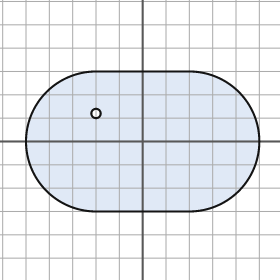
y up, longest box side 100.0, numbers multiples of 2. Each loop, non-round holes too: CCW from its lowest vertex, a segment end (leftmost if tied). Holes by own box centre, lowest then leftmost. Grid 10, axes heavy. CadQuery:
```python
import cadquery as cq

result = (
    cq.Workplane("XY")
    .moveTo(-20.0, -30.0)
    .lineTo(20.0, -30.0)
    .threePointArc((50.0, 0.0), (20.0, 30.0))
    .lineTo(-20.0, 30.0)
    .threePointArc((-50.0, 0.0), (-20.0, -30.0))
    .close()
    .moveTo(-20.0, 12.0)
    .circle(2.0)
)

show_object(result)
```